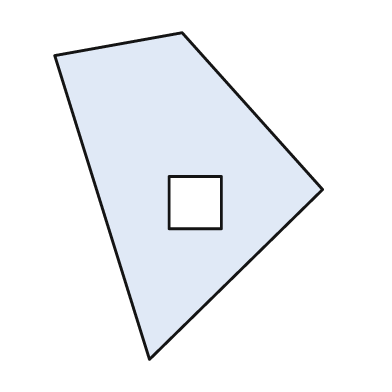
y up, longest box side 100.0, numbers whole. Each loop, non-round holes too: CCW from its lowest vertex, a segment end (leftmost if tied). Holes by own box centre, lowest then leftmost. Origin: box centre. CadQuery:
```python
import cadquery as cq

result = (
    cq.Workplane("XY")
    .moveTo(-12.0, -50.0)
    .lineTo(41.0, 2.0)
    .lineTo(-2.0, 50.0)
    .lineTo(-41.0, 43.0)
    .close()
    .moveTo(-6.0, -10.0)
    .lineTo(10.0, -10.0)
    .lineTo(10.0, 6.0)
    .lineTo(-6.0, 6.0)
    .close()
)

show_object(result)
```